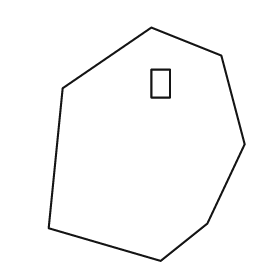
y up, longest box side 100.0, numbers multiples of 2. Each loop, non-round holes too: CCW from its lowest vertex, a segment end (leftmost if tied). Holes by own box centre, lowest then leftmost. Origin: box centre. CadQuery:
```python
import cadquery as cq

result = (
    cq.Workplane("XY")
    .moveTo(6.0, -50.0)
    .lineTo(26.0, -34.0)
    .lineTo(42.0, 0.0)
    .lineTo(32.0, 38.0)
    .lineTo(2.0, 50.0)
    .lineTo(-36.0, 24.0)
    .lineTo(-42.0, -36.0)
    .close()
    .moveTo(2.0, 20.0)
    .lineTo(10.0, 20.0)
    .lineTo(10.0, 32.0)
    .lineTo(2.0, 32.0)
    .close()
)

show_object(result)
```